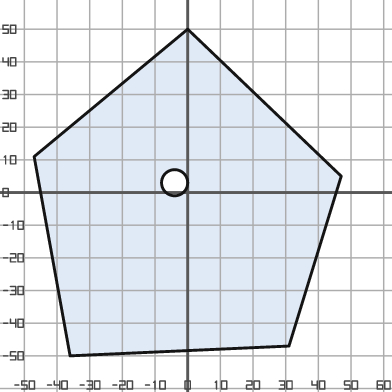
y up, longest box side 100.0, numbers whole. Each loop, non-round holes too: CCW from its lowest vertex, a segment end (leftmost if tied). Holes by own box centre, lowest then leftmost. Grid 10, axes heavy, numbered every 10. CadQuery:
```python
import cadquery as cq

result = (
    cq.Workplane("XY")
    .moveTo(-36.0, -50.0)
    .lineTo(31.0, -47.0)
    .lineTo(47.0, 5.0)
    .lineTo(0.0, 50.0)
    .lineTo(-47.0, 11.0)
    .close()
    .moveTo(-4.0, 3.0)
    .circle(4.0)
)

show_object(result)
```